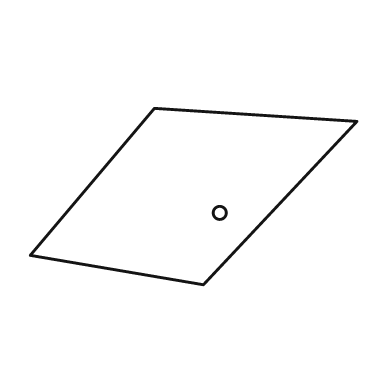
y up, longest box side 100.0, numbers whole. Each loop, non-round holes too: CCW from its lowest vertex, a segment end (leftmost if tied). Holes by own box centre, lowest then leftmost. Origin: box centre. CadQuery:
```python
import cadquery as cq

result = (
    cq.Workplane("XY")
    .moveTo(3.0, -27.0)
    .lineTo(50.0, 23.0)
    .lineTo(-12.0, 27.0)
    .lineTo(-50.0, -18.0)
    .close()
    .moveTo(8.0, -5.0)
    .circle(2.0)
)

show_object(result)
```